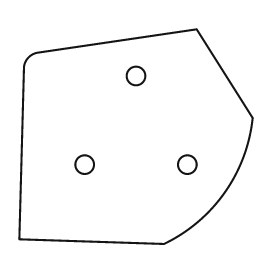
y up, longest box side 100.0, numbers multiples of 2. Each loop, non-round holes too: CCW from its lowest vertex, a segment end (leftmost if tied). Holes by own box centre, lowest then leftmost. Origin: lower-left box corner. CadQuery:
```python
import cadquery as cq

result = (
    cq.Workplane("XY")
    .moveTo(62.0, 0.0)
    .threePointArc((88.0, 22.0), (100.0, 54.0))
    .lineTo(76.0, 92.0)
    .lineTo(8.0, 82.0)
    .threePointArc((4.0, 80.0), (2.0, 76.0))
    .lineTo(0.0, 2.0)
    .close()
    .moveTo(28.0, 34.0)
    .circle(4.0)
    .moveTo(72.0, 34.0)
    .circle(4.0)
    .moveTo(50.0, 72.0)
    .circle(4.0)
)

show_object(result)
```